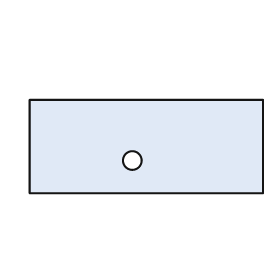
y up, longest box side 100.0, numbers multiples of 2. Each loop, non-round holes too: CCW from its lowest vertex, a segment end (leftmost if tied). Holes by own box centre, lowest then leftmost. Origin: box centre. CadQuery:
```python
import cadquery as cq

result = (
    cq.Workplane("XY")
    .moveTo(-50.0, -20.0)
    .lineTo(50.0, -20.0)
    .lineTo(50.0, 20.0)
    .lineTo(-50.0, 20.0)
    .close()
    .moveTo(-6.0, -6.0)
    .circle(4.0)
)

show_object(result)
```